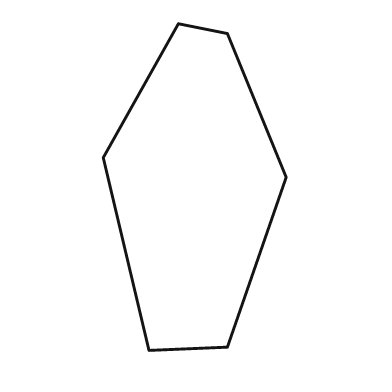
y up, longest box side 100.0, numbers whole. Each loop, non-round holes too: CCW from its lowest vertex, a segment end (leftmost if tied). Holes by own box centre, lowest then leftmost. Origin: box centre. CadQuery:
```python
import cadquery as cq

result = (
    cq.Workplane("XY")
    .moveTo(-14.0, -50.0)
    .lineTo(10.0, -49.0)
    .lineTo(28.0, 3.0)
    .lineTo(10.0, 47.0)
    .lineTo(-5.0, 50.0)
    .lineTo(-28.0, 9.0)
    .close()
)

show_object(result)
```